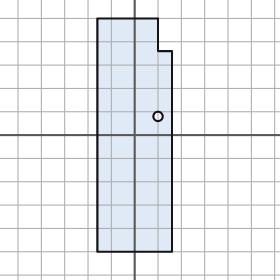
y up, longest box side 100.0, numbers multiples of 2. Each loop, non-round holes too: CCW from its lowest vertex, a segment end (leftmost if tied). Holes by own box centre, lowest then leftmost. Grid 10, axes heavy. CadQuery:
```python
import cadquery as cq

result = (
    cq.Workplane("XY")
    .moveTo(-16.0, -50.0)
    .lineTo(16.0, -50.0)
    .lineTo(16.0, 36.0)
    .lineTo(10.0, 36.0)
    .lineTo(10.0, 50.0)
    .lineTo(-16.0, 50.0)
    .close()
    .moveTo(10.0, 8.0)
    .circle(2.0)
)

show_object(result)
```